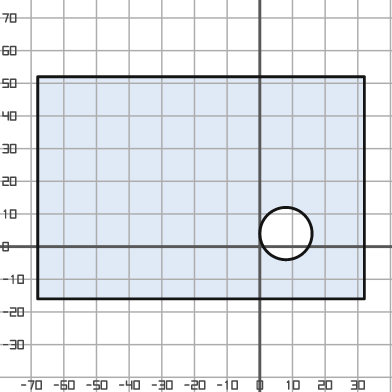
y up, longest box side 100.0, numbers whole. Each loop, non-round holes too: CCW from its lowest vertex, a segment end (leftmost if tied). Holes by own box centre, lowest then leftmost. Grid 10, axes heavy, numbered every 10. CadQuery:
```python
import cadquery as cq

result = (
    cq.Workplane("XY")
    .moveTo(-68.0, -16.0)
    .lineTo(32.0, -16.0)
    .lineTo(32.0, 52.0)
    .lineTo(-68.0, 52.0)
    .close()
    .moveTo(8.0, 4.0)
    .circle(8.0)
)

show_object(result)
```